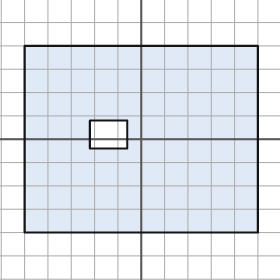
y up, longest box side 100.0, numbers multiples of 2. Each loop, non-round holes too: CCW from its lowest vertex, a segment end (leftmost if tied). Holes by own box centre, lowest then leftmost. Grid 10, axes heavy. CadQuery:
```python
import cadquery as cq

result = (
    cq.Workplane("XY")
    .moveTo(-50.0, -40.0)
    .lineTo(50.0, -40.0)
    .lineTo(50.0, 40.0)
    .lineTo(-50.0, 40.0)
    .close()
    .moveTo(-22.0, -4.0)
    .lineTo(-6.0, -4.0)
    .lineTo(-6.0, 8.0)
    .lineTo(-22.0, 8.0)
    .close()
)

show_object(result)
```